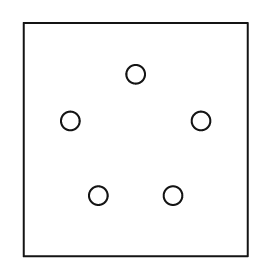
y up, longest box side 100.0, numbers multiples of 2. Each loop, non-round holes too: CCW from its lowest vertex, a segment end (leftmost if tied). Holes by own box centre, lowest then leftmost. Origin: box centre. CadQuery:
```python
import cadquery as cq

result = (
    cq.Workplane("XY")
    .moveTo(-48.0, -50.0)
    .lineTo(48.0, -50.0)
    .lineTo(48.0, 50.0)
    .lineTo(-48.0, 50.0)
    .close()
    .moveTo(-16.0, -24.0)
    .circle(4.0)
    .moveTo(16.0, -24.0)
    .circle(4.0)
    .moveTo(-28.0, 8.0)
    .circle(4.0)
    .moveTo(28.0, 8.0)
    .circle(4.0)
    .moveTo(0.0, 28.0)
    .circle(4.0)
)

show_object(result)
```